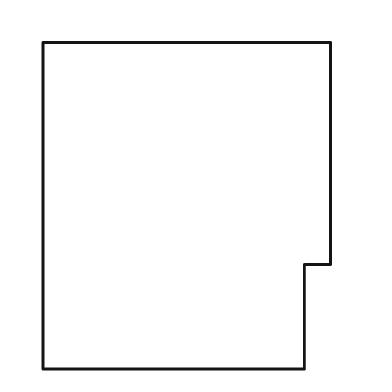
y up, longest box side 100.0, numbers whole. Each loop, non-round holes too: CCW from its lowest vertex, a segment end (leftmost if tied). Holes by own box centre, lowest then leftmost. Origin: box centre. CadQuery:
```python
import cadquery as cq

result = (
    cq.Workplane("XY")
    .moveTo(-44.0, -50.0)
    .lineTo(36.0, -50.0)
    .lineTo(36.0, -18.0)
    .lineTo(44.0, -18.0)
    .lineTo(44.0, 50.0)
    .lineTo(-44.0, 50.0)
    .close()
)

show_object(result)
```